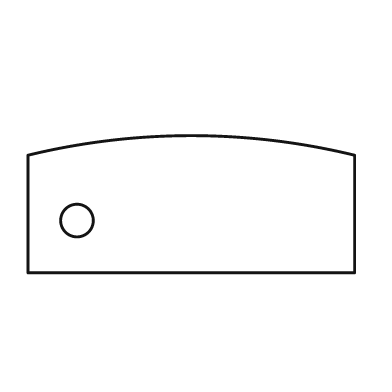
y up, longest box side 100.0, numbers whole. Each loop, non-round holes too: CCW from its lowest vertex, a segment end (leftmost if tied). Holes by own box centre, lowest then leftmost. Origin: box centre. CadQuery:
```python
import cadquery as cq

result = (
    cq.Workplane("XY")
    .moveTo(-50.0, -21.0)
    .lineTo(50.0, -21.0)
    .lineTo(50.0, 15.0)
    .threePointArc((0.0, 21.0), (-50.0, 15.0))
    .close()
    .moveTo(-35.0, -5.0)
    .circle(5.0)
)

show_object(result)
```